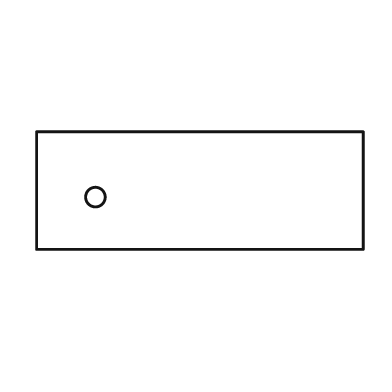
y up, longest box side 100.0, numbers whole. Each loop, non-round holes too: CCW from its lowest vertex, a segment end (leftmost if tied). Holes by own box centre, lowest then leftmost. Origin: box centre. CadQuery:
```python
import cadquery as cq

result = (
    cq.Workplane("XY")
    .moveTo(-50.0, -18.0)
    .lineTo(50.0, -18.0)
    .lineTo(50.0, 18.0)
    .lineTo(-50.0, 18.0)
    .close()
    .moveTo(-32.0, -2.0)
    .circle(3.0)
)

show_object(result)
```